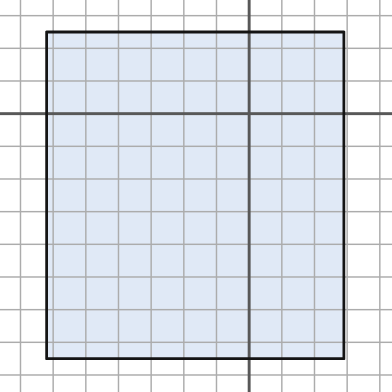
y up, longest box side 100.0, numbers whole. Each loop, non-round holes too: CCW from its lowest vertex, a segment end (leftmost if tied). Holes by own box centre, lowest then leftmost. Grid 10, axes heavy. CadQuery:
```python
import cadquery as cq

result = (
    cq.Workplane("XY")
    .moveTo(-62.0, -75.0)
    .lineTo(29.0, -75.0)
    .lineTo(29.0, 25.0)
    .lineTo(-62.0, 25.0)
    .close()
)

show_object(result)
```